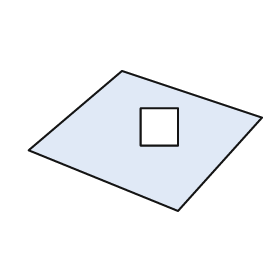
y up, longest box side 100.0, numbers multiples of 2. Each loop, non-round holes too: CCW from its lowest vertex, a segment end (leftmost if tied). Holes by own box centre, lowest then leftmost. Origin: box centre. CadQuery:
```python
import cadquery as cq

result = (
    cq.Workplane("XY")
    .moveTo(14.0, -30.0)
    .lineTo(50.0, 10.0)
    .lineTo(-10.0, 30.0)
    .lineTo(-50.0, -4.0)
    .close()
    .moveTo(-2.0, -2.0)
    .lineTo(14.0, -2.0)
    .lineTo(14.0, 14.0)
    .lineTo(-2.0, 14.0)
    .close()
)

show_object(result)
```